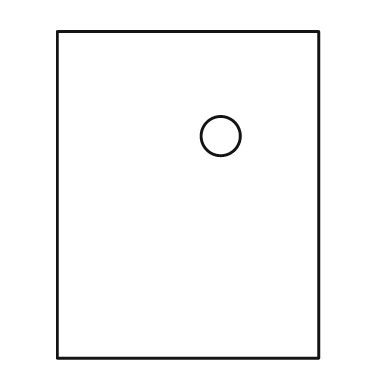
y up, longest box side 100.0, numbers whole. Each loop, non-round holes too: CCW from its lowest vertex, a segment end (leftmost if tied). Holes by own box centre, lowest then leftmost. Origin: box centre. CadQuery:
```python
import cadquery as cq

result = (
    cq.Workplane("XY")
    .moveTo(-40.0, -50.0)
    .lineTo(40.0, -50.0)
    .lineTo(40.0, 50.0)
    .lineTo(-40.0, 50.0)
    .close()
    .moveTo(10.0, 18.0)
    .circle(6.0)
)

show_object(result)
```